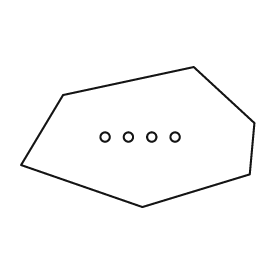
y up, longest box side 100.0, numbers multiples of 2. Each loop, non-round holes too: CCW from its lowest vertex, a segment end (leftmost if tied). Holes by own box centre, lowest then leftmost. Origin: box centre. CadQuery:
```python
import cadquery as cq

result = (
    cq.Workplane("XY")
    .moveTo(2.0, -30.0)
    .lineTo(48.0, -16.0)
    .lineTo(50.0, 6.0)
    .lineTo(24.0, 30.0)
    .lineTo(-32.0, 18.0)
    .lineTo(-50.0, -12.0)
    .close()
    .moveTo(-14.0, 0.0)
    .circle(2.0)
    .moveTo(-4.0, 0.0)
    .circle(2.0)
    .moveTo(6.0, 0.0)
    .circle(2.0)
    .moveTo(16.0, 0.0)
    .circle(2.0)
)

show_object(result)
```